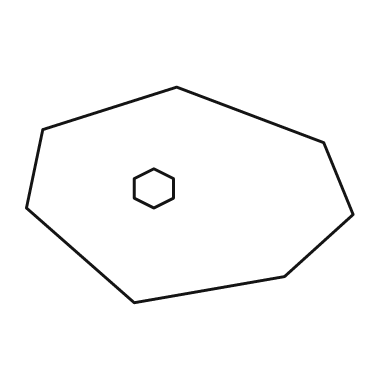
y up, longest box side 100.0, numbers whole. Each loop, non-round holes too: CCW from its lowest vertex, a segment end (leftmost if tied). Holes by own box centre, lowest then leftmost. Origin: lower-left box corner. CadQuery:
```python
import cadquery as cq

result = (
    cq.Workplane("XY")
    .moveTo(33.0, 0.0)
    .lineTo(79.0, 8.0)
    .lineTo(100.0, 27.0)
    .lineTo(91.0, 49.0)
    .lineTo(46.0, 66.0)
    .lineTo(5.0, 53.0)
    .lineTo(0.0, 29.0)
    .close()
    .moveTo(39.0, 29.0)
    .lineTo(45.0, 32.0)
    .lineTo(45.0, 38.0)
    .lineTo(39.0, 41.0)
    .lineTo(33.0, 38.0)
    .lineTo(33.0, 32.0)
    .close()
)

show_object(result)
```